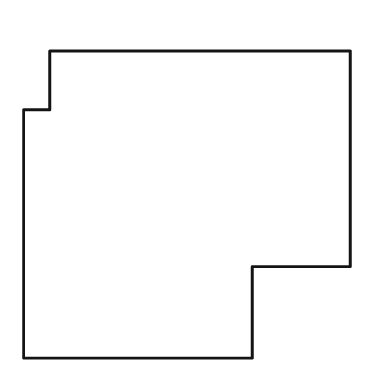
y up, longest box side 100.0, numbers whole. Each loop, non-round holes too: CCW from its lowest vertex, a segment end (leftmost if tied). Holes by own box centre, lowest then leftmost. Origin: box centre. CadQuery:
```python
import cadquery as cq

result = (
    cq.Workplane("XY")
    .moveTo(-50.0, -47.0)
    .lineTo(20.0, -47.0)
    .lineTo(20.0, -19.0)
    .lineTo(50.0, -19.0)
    .lineTo(50.0, 47.0)
    .lineTo(-42.0, 47.0)
    .lineTo(-42.0, 29.0)
    .lineTo(-50.0, 29.0)
    .close()
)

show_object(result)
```